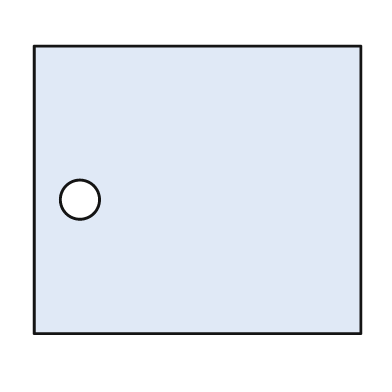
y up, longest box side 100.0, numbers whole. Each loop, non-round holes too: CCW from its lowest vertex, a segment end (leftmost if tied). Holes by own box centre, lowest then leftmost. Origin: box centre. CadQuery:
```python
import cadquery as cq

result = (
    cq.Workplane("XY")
    .moveTo(-50.0, -44.0)
    .lineTo(50.0, -44.0)
    .lineTo(50.0, 44.0)
    .lineTo(-50.0, 44.0)
    .close()
    .moveTo(-36.0, -3.0)
    .circle(6.0)
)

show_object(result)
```